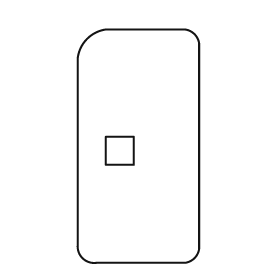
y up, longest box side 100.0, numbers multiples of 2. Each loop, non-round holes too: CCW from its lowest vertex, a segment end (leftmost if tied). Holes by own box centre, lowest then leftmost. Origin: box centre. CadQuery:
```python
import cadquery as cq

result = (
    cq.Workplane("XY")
    .moveTo(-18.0, -50.0)
    .lineTo(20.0, -50.0)
    .threePointArc((24.0, -48.0), (26.0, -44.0))
    .lineTo(26.0, 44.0)
    .threePointArc((24.0, 48.0), (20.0, 50.0))
    .lineTo(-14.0, 50.0)
    .threePointArc((-22.0, 46.0), (-26.0, 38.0))
    .lineTo(-26.0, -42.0)
    .threePointArc((-24.0, -48.0), (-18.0, -50.0))
    .close()
    .moveTo(-14.0, -8.0)
    .lineTo(-2.0, -8.0)
    .lineTo(-2.0, 4.0)
    .lineTo(-14.0, 4.0)
    .close()
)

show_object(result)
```